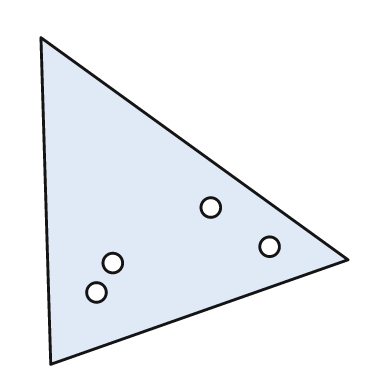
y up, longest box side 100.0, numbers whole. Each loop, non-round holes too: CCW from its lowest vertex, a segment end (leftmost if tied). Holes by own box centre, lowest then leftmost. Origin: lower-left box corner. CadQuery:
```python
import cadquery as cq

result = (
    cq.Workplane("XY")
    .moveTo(3.0, 0.0)
    .lineTo(94.0, 32.0)
    .lineTo(0.0, 100.0)
    .close()
    .moveTo(17.0, 22.0)
    .circle(3.0)
    .moveTo(22.0, 31.0)
    .circle(3.0)
    .moveTo(70.0, 36.0)
    .circle(3.0)
    .moveTo(52.0, 48.0)
    .circle(3.0)
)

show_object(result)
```